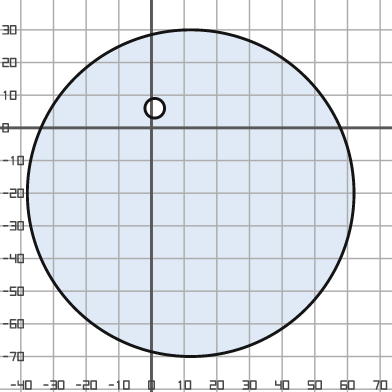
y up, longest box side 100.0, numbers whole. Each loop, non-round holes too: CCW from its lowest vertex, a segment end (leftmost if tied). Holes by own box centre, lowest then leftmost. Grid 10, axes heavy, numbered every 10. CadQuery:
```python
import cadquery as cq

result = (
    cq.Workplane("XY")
    .moveTo(12.0, -20.0)
    .circle(50.0)
    .moveTo(1.0, 6.0)
    .circle(3.0)
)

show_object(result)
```